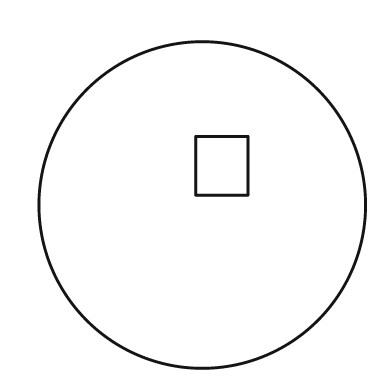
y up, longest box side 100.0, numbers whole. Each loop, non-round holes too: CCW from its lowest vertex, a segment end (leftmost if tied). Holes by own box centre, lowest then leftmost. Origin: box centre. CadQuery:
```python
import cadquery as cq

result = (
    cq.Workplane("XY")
    .moveTo(0.0, 0.0)
    .circle(50.0)
    .moveTo(-2.0, 3.0)
    .lineTo(14.0, 3.0)
    .lineTo(14.0, 21.0)
    .lineTo(-2.0, 21.0)
    .close()
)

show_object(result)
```